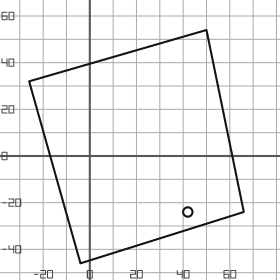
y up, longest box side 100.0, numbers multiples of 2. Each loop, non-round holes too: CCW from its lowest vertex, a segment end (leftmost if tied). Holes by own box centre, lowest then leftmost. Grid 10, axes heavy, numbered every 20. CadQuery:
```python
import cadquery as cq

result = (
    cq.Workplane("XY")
    .moveTo(-4.0, -46.0)
    .lineTo(66.0, -24.0)
    .lineTo(50.0, 54.0)
    .lineTo(-26.0, 32.0)
    .close()
    .moveTo(42.0, -24.0)
    .circle(2.0)
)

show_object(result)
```